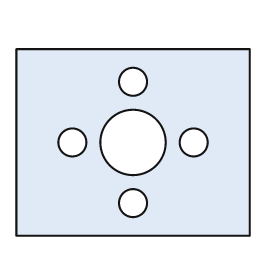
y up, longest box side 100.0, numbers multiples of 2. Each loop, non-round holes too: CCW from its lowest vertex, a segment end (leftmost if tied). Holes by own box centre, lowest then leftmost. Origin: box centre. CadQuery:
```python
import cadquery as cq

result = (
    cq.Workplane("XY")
    .moveTo(-50.0, -40.0)
    .lineTo(50.0, -40.0)
    .lineTo(50.0, 40.0)
    .lineTo(-50.0, 40.0)
    .close()
    .moveTo(0.0, -26.0)
    .circle(6.0)
    .moveTo(-26.0, 0.0)
    .circle(6.0)
    .moveTo(0.0, 0.0)
    .circle(14.0)
    .moveTo(26.0, 0.0)
    .circle(6.0)
    .moveTo(0.0, 26.0)
    .circle(6.0)
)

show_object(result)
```